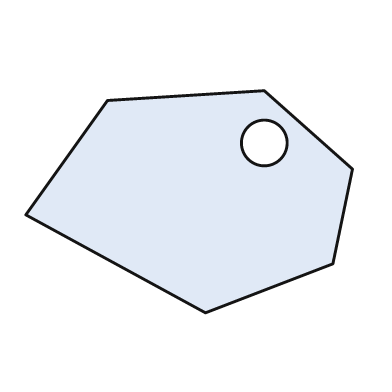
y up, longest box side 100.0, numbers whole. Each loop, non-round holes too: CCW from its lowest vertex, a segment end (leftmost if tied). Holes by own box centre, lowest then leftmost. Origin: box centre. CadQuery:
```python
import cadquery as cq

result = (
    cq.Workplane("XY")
    .moveTo(5.0, -34.0)
    .lineTo(44.0, -19.0)
    .lineTo(50.0, 10.0)
    .lineTo(23.0, 34.0)
    .lineTo(-25.0, 31.0)
    .lineTo(-50.0, -4.0)
    .close()
    .moveTo(23.0, 18.0)
    .circle(7.0)
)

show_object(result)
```